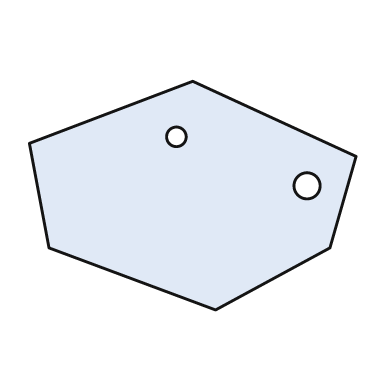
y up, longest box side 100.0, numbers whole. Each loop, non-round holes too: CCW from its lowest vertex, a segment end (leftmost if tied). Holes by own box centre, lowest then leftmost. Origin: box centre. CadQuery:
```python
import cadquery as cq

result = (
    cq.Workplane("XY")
    .moveTo(7.0, -35.0)
    .lineTo(42.0, -16.0)
    .lineTo(50.0, 12.0)
    .lineTo(0.0, 35.0)
    .lineTo(-50.0, 16.0)
    .lineTo(-44.0, -16.0)
    .close()
    .moveTo(35.0, 3.0)
    .circle(4.0)
    .moveTo(-5.0, 18.0)
    .circle(3.0)
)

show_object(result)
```